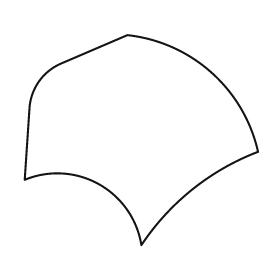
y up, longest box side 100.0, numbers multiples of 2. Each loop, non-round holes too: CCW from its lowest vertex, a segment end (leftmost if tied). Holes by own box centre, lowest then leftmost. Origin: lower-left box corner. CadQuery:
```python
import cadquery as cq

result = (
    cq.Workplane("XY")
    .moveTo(50.0, 0.0)
    .threePointArc((72.0, 24.0), (100.0, 40.0))
    .threePointArc((80.0, 74.0), (44.0, 90.0))
    .lineTo(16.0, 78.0)
    .threePointArc((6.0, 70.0), (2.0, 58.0))
    .lineTo(0.0, 28.0)
    .threePointArc((32.0, 26.0), (50.0, 0.0))
    .close()
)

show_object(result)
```